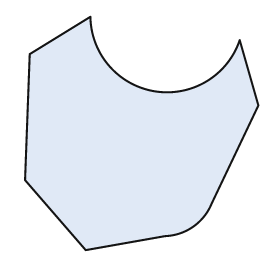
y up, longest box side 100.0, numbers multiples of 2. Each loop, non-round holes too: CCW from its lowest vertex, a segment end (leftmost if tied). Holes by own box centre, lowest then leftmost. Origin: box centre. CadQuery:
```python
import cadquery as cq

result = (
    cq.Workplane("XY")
    .moveTo(-24.0, -50.0)
    .lineTo(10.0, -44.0)
    .threePointArc((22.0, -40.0), (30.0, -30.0))
    .lineTo(50.0, 12.0)
    .lineTo(42.0, 40.0)
    .threePointArc((6.0, 18.0), (-22.0, 50.0))
    .lineTo(-48.0, 34.0)
    .lineTo(-50.0, -20.0)
    .close()
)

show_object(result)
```